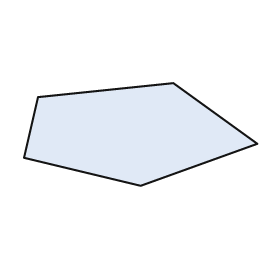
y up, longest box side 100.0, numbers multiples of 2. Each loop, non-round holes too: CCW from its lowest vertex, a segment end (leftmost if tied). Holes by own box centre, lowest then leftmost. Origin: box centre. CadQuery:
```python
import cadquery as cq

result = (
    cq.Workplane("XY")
    .moveTo(0.0, -22.0)
    .lineTo(50.0, -4.0)
    .lineTo(14.0, 22.0)
    .lineTo(-44.0, 16.0)
    .lineTo(-50.0, -10.0)
    .close()
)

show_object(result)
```